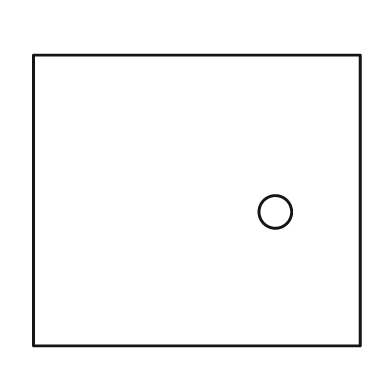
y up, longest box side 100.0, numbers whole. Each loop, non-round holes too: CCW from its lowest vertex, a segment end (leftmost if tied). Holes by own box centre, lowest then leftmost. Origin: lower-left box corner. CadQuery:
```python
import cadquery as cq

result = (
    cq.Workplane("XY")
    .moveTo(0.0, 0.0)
    .lineTo(100.0, 0.0)
    .lineTo(100.0, 89.0)
    .lineTo(0.0, 89.0)
    .close()
    .moveTo(74.0, 41.0)
    .circle(5.0)
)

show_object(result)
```